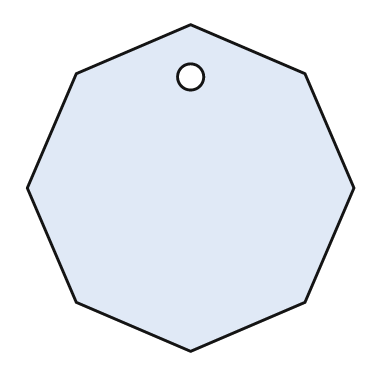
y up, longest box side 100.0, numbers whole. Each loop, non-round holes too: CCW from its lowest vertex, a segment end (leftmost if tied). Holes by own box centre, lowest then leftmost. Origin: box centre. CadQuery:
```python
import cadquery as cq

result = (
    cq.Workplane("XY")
    .moveTo(0.0, -50.0)
    .lineTo(35.0, -35.0)
    .lineTo(50.0, 0.0)
    .lineTo(35.0, 35.0)
    .lineTo(0.0, 50.0)
    .lineTo(-35.0, 35.0)
    .lineTo(-50.0, 0.0)
    .lineTo(-35.0, -35.0)
    .close()
    .moveTo(0.0, 34.0)
    .circle(4.0)
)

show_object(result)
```